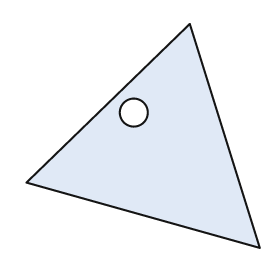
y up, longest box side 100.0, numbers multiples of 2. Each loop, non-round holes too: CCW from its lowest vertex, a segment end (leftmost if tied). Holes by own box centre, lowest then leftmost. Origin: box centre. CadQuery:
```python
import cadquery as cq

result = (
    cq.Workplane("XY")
    .moveTo(50.0, -48.0)
    .lineTo(20.0, 48.0)
    .lineTo(-50.0, -20.0)
    .close()
    .moveTo(-4.0, 10.0)
    .circle(6.0)
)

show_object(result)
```